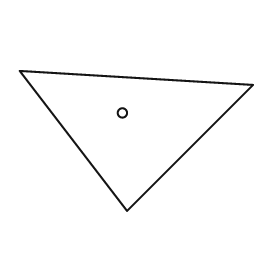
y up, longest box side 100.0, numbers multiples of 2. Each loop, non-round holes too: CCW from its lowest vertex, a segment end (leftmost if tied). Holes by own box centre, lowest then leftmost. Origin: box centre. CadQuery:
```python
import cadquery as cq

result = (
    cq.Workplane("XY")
    .moveTo(-4.0, -30.0)
    .lineTo(50.0, 24.0)
    .lineTo(-50.0, 30.0)
    .close()
    .moveTo(-6.0, 12.0)
    .circle(2.0)
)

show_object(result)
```